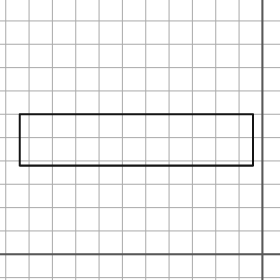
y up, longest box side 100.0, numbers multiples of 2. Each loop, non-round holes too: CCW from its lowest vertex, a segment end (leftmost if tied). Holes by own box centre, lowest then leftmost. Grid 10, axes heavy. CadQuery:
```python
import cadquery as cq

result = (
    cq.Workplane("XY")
    .moveTo(-104.0, 38.0)
    .lineTo(-4.0, 38.0)
    .lineTo(-4.0, 60.0)
    .lineTo(-104.0, 60.0)
    .close()
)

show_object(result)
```